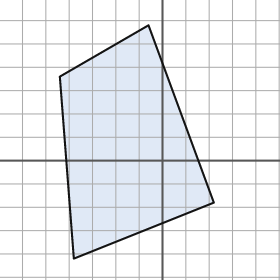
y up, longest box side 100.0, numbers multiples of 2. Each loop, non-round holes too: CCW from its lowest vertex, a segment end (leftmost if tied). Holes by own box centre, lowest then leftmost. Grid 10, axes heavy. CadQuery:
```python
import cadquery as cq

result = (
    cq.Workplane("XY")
    .moveTo(-38.0, -42.0)
    .lineTo(22.0, -18.0)
    .lineTo(-6.0, 58.0)
    .lineTo(-44.0, 36.0)
    .close()
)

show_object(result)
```